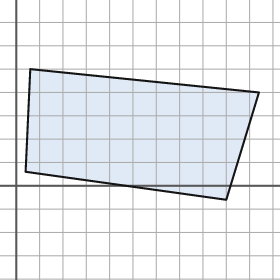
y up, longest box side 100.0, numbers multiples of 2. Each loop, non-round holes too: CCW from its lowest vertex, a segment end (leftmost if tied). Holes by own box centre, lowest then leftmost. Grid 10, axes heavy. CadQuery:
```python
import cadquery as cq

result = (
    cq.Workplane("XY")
    .moveTo(90.0, -6.0)
    .lineTo(104.0, 40.0)
    .lineTo(6.0, 50.0)
    .lineTo(4.0, 6.0)
    .close()
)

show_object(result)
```